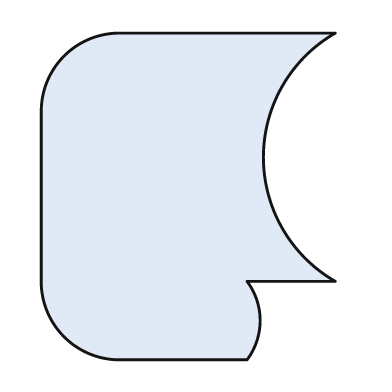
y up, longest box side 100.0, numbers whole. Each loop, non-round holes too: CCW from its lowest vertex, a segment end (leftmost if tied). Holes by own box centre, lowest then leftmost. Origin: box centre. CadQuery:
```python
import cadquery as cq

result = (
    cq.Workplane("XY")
    .moveTo(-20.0, -50.0)
    .lineTo(18.0, -50.0)
    .threePointArc((22.0, -38.0), (18.0, -26.0))
    .lineTo(45.0, -26.0)
    .threePointArc((23.0, 12.0), (45.0, 50.0))
    .lineTo(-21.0, 50.0)
    .threePointArc((-38.0, 43.0), (-45.0, 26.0))
    .lineTo(-45.0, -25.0)
    .threePointArc((-38.0, -43.0), (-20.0, -50.0))
    .close()
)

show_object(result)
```